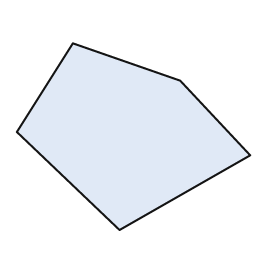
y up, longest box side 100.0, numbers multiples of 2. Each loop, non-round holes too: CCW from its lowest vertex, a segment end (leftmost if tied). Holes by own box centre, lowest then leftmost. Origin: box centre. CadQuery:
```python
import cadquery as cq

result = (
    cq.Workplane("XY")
    .moveTo(-6.0, -40.0)
    .lineTo(50.0, -8.0)
    .lineTo(20.0, 24.0)
    .lineTo(-26.0, 40.0)
    .lineTo(-50.0, 2.0)
    .close()
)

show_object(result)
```